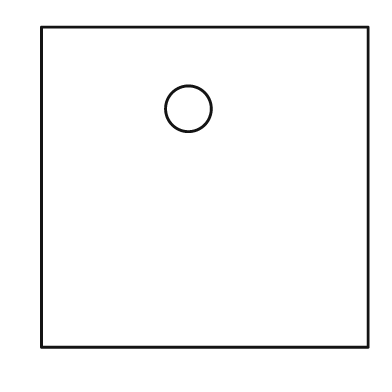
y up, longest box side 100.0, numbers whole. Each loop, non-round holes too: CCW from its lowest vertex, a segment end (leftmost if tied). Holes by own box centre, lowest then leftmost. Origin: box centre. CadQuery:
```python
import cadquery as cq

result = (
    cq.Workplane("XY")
    .moveTo(-50.0, -49.0)
    .lineTo(50.0, -49.0)
    .lineTo(50.0, 49.0)
    .lineTo(-50.0, 49.0)
    .close()
    .moveTo(-5.0, 24.0)
    .circle(7.0)
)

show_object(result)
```